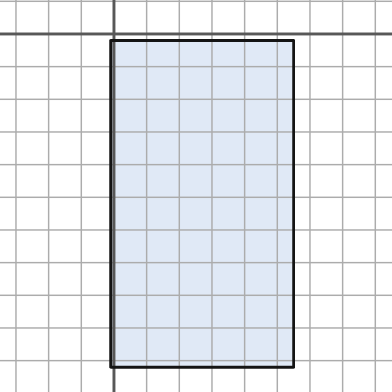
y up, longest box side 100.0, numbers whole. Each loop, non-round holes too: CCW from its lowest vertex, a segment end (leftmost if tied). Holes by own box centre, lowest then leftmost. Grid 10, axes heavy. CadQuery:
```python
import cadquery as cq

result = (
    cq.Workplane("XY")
    .moveTo(-1.0, -102.0)
    .lineTo(55.0, -102.0)
    .lineTo(55.0, -2.0)
    .lineTo(-1.0, -2.0)
    .close()
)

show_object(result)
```